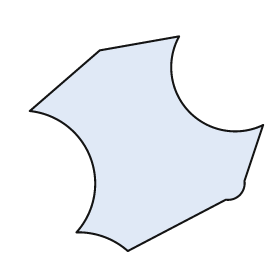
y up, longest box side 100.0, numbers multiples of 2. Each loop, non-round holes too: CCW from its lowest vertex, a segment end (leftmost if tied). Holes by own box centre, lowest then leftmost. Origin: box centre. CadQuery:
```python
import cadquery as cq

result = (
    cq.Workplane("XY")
    .moveTo(-8.0, -46.0)
    .lineTo(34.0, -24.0)
    .threePointArc((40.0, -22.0), (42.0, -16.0))
    .lineTo(50.0, 8.0)
    .threePointArc((18.0, 14.0), (14.0, 46.0))
    .lineTo(-20.0, 40.0)
    .lineTo(-50.0, 14.0)
    .threePointArc((-24.0, -6.0), (-30.0, -38.0))
    .threePointArc((-18.0, -40.0), (-8.0, -46.0))
    .close()
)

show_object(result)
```